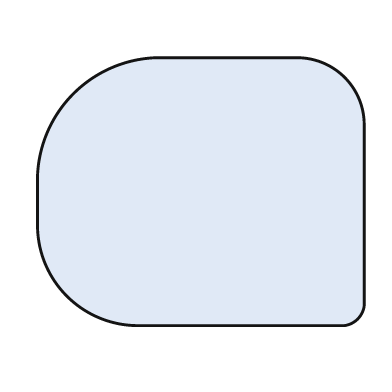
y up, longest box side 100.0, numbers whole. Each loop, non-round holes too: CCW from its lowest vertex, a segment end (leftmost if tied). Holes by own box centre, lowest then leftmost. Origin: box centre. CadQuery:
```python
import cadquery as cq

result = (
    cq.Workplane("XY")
    .moveTo(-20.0, -41.0)
    .lineTo(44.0, -41.0)
    .threePointArc((48.0, -39.0), (50.0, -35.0))
    .lineTo(50.0, 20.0)
    .threePointArc((44.0, 35.0), (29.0, 41.0))
    .lineTo(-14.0, 41.0)
    .threePointArc((-39.0, 30.0), (-50.0, 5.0))
    .lineTo(-50.0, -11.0)
    .threePointArc((-41.0, -32.0), (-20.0, -41.0))
    .close()
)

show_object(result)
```